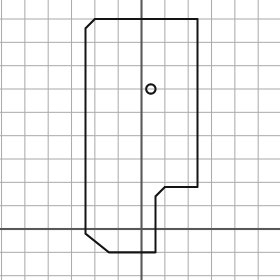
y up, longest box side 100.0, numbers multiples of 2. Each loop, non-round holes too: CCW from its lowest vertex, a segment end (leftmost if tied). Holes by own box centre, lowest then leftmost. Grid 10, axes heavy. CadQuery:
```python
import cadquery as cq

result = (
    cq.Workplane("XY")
    .moveTo(-14.0, -10.0)
    .lineTo(6.0, -10.0)
    .lineTo(6.0, 14.0)
    .lineTo(10.0, 18.0)
    .lineTo(24.0, 18.0)
    .lineTo(24.0, 90.0)
    .lineTo(-20.0, 90.0)
    .lineTo(-24.0, 86.0)
    .lineTo(-24.0, -2.0)
    .close()
    .moveTo(4.0, 60.0)
    .circle(2.0)
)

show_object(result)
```